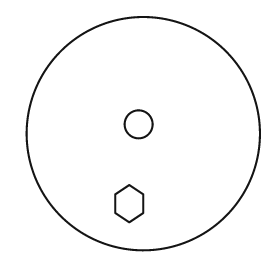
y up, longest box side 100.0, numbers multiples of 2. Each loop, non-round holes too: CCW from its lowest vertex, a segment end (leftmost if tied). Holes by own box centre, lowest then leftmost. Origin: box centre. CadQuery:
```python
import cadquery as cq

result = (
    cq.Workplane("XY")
    .moveTo(0.0, 0.0)
    .circle(50.0)
    .moveTo(-6.0, -38.0)
    .lineTo(0.0, -34.0)
    .lineTo(0.0, -26.0)
    .lineTo(-6.0, -22.0)
    .lineTo(-12.0, -26.0)
    .lineTo(-12.0, -34.0)
    .close()
    .moveTo(-2.0, 4.0)
    .circle(6.0)
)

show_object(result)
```